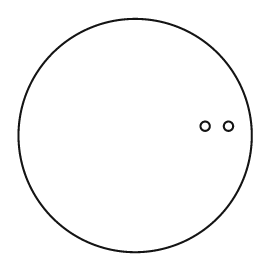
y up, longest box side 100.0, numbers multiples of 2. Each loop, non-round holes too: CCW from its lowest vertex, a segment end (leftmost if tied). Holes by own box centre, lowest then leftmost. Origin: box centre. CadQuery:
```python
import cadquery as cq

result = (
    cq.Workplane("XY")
    .moveTo(0.0, 0.0)
    .circle(50.0)
    .moveTo(30.0, 4.0)
    .circle(2.0)
    .moveTo(40.0, 4.0)
    .circle(2.0)
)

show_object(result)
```